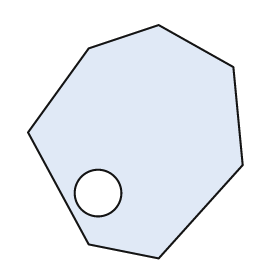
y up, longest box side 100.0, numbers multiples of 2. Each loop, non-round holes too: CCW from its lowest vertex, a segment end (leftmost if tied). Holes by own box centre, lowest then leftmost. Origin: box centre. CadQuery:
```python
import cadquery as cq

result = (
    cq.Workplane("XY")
    .moveTo(10.0, -50.0)
    .lineTo(46.0, -10.0)
    .lineTo(42.0, 32.0)
    .lineTo(10.0, 50.0)
    .lineTo(-20.0, 40.0)
    .lineTo(-46.0, 4.0)
    .lineTo(-20.0, -44.0)
    .close()
    .moveTo(-16.0, -22.0)
    .circle(10.0)
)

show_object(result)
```